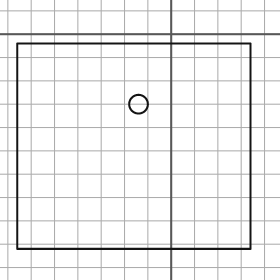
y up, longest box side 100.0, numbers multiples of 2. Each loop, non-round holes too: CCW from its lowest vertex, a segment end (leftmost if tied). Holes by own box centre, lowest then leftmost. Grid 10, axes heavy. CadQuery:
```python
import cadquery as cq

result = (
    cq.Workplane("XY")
    .moveTo(-66.0, -92.0)
    .lineTo(34.0, -92.0)
    .lineTo(34.0, -4.0)
    .lineTo(-66.0, -4.0)
    .close()
    .moveTo(-14.0, -30.0)
    .circle(4.0)
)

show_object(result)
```